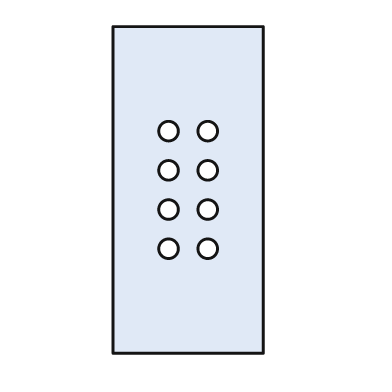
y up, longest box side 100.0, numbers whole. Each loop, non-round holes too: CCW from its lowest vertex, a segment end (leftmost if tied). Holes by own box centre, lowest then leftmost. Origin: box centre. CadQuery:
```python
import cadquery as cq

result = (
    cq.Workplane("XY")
    .moveTo(-23.0, -50.0)
    .lineTo(23.0, -50.0)
    .lineTo(23.0, 50.0)
    .lineTo(-23.0, 50.0)
    .close()
    .moveTo(-6.0, -18.0)
    .circle(3.0)
    .moveTo(6.0, -18.0)
    .circle(3.0)
    .moveTo(-6.0, -6.0)
    .circle(3.0)
    .moveTo(6.0, -6.0)
    .circle(3.0)
    .moveTo(-6.0, 6.0)
    .circle(3.0)
    .moveTo(6.0, 6.0)
    .circle(3.0)
    .moveTo(-6.0, 18.0)
    .circle(3.0)
    .moveTo(6.0, 18.0)
    .circle(3.0)
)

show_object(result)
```